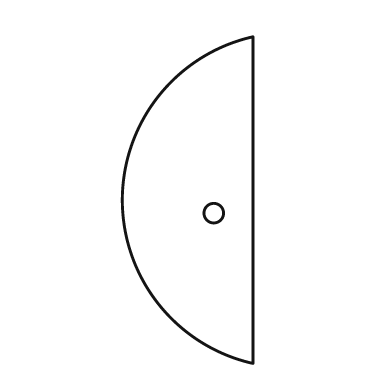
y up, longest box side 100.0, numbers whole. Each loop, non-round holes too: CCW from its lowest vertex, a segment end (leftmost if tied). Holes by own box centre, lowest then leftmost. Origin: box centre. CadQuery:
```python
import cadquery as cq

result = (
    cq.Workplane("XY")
    .moveTo(20.0, -50.0)
    .lineTo(20.0, 50.0)
    .threePointArc((-20.0, 0.0), (20.0, -50.0))
    .close()
    .moveTo(8.0, -4.0)
    .circle(3.0)
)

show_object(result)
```